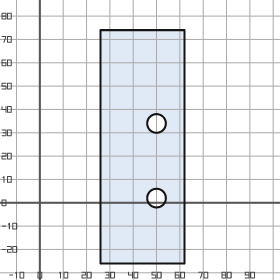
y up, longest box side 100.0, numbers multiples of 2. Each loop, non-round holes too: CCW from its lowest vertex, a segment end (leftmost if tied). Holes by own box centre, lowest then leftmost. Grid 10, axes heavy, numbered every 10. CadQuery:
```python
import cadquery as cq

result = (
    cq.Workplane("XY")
    .moveTo(26.0, -26.0)
    .lineTo(62.0, -26.0)
    .lineTo(62.0, 74.0)
    .lineTo(26.0, 74.0)
    .close()
    .moveTo(50.0, 2.0)
    .circle(4.0)
    .moveTo(50.0, 34.0)
    .circle(4.0)
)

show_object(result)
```